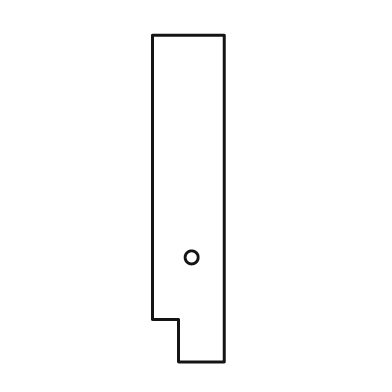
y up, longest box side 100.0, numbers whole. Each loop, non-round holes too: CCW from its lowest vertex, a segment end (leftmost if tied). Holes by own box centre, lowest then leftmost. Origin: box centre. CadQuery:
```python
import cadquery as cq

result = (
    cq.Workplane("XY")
    .moveTo(-3.0, -50.0)
    .lineTo(11.0, -50.0)
    .lineTo(11.0, 50.0)
    .lineTo(-11.0, 50.0)
    .lineTo(-11.0, -37.0)
    .lineTo(-3.0, -37.0)
    .close()
    .moveTo(1.0, -18.0)
    .circle(2.0)
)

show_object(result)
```